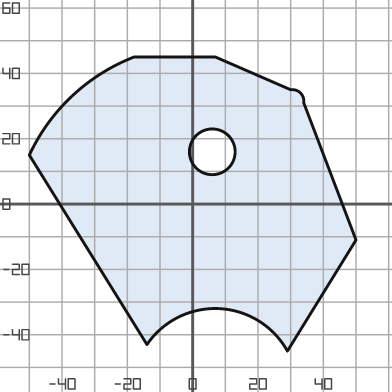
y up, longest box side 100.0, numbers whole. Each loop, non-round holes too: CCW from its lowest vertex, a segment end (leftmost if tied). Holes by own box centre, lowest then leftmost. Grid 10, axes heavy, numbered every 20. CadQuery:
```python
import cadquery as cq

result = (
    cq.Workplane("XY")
    .moveTo(29.0, -45.0)
    .lineTo(50.0, -11.0)
    .lineTo(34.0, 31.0)
    .threePointArc((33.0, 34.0), (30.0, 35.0))
    .lineTo(7.0, 45.0)
    .lineTo(-18.0, 45.0)
    .threePointArc((-37.0, 33.0), (-50.0, 15.0))
    .lineTo(-14.0, -43.0)
    .threePointArc((8.0, -32.0), (29.0, -45.0))
    .close()
    .moveTo(6.0, 16.0)
    .circle(7.0)
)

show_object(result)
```